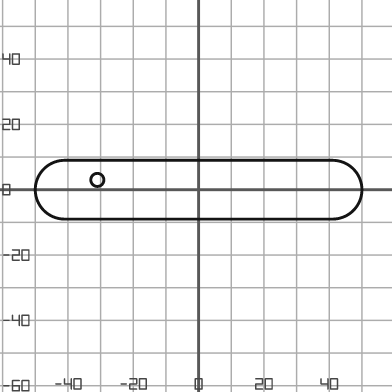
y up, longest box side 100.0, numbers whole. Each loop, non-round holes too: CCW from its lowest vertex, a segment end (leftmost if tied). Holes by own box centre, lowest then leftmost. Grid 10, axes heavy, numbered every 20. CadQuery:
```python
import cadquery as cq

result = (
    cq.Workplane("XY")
    .moveTo(-41.0, -9.0)
    .lineTo(41.0, -9.0)
    .threePointArc((50.0, 0.0), (41.0, 9.0))
    .lineTo(-41.0, 9.0)
    .threePointArc((-50.0, 0.0), (-41.0, -9.0))
    .close()
    .moveTo(-31.0, 3.0)
    .circle(2.0)
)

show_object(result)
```